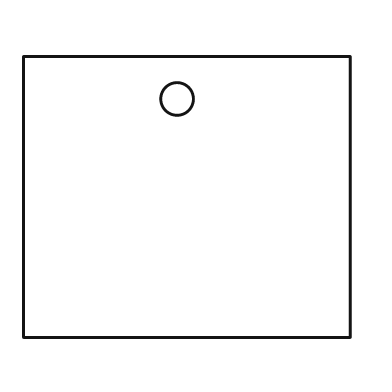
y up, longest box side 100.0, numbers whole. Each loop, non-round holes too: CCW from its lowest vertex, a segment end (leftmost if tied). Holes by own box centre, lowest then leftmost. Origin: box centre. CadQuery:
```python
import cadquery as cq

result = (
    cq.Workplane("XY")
    .moveTo(-50.0, -43.0)
    .lineTo(50.0, -43.0)
    .lineTo(50.0, 43.0)
    .lineTo(-50.0, 43.0)
    .close()
    .moveTo(-3.0, 30.0)
    .circle(5.0)
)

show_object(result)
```